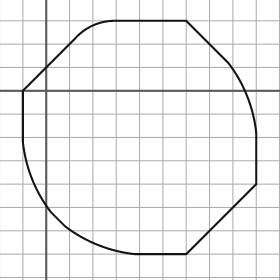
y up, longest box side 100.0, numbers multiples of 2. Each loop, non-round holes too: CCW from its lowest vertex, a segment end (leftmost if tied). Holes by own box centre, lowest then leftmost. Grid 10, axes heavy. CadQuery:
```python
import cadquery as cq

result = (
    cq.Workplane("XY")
    .moveTo(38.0, -70.0)
    .lineTo(60.0, -70.0)
    .lineTo(90.0, -40.0)
    .lineTo(90.0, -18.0)
    .threePointArc((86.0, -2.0), (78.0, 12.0))
    .lineTo(60.0, 30.0)
    .lineTo(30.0, 30.0)
    .threePointArc((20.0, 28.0), (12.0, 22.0))
    .lineTo(-10.0, 0.0)
    .lineTo(-10.0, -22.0)
    .threePointArc((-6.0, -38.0), (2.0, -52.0))
    .lineTo(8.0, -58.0)
    .threePointArc((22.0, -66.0), (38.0, -70.0))
    .close()
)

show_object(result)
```